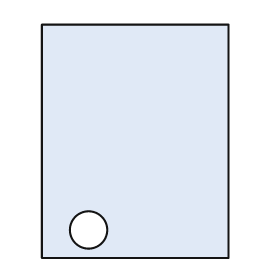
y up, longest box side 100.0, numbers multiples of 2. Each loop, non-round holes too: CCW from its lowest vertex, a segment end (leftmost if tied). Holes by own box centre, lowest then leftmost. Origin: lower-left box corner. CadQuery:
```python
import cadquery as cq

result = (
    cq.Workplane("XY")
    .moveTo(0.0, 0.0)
    .lineTo(80.0, 0.0)
    .lineTo(80.0, 100.0)
    .lineTo(0.0, 100.0)
    .close()
    .moveTo(20.0, 12.0)
    .circle(8.0)
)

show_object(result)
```